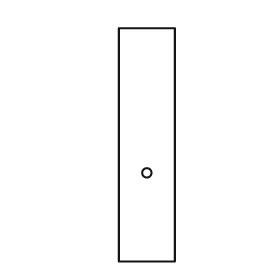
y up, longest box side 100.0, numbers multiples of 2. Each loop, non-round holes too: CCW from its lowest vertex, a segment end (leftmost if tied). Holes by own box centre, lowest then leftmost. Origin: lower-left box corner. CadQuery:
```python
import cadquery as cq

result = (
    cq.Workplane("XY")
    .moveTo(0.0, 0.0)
    .lineTo(24.0, 0.0)
    .lineTo(24.0, 100.0)
    .lineTo(0.0, 100.0)
    .close()
    .moveTo(12.0, 38.0)
    .circle(2.0)
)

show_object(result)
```